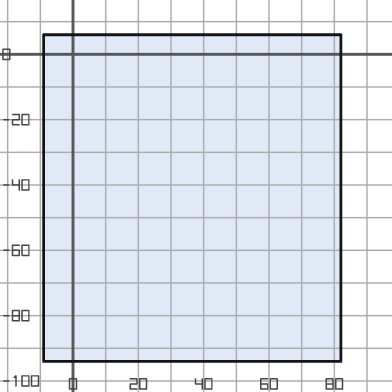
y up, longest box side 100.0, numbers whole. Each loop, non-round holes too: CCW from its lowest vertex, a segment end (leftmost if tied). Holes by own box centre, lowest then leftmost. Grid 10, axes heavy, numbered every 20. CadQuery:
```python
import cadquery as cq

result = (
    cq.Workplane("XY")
    .moveTo(-9.0, -94.0)
    .lineTo(82.0, -94.0)
    .lineTo(82.0, 6.0)
    .lineTo(-9.0, 6.0)
    .close()
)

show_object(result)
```